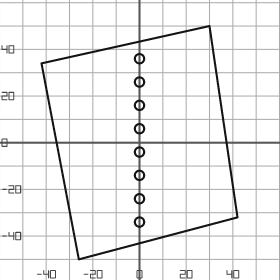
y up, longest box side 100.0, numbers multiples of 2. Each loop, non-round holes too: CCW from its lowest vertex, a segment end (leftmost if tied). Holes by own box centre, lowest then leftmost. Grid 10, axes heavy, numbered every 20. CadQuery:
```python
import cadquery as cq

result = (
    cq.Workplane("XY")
    .moveTo(-26.0, -50.0)
    .lineTo(42.0, -32.0)
    .lineTo(30.0, 50.0)
    .lineTo(-42.0, 34.0)
    .close()
    .moveTo(0.0, -34.0)
    .circle(2.0)
    .moveTo(0.0, -24.0)
    .circle(2.0)
    .moveTo(0.0, -14.0)
    .circle(2.0)
    .moveTo(0.0, -4.0)
    .circle(2.0)
    .moveTo(0.0, 6.0)
    .circle(2.0)
    .moveTo(0.0, 16.0)
    .circle(2.0)
    .moveTo(0.0, 26.0)
    .circle(2.0)
    .moveTo(0.0, 36.0)
    .circle(2.0)
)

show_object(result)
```